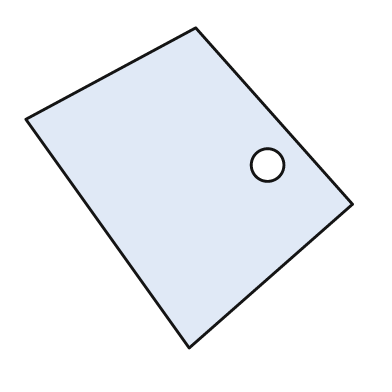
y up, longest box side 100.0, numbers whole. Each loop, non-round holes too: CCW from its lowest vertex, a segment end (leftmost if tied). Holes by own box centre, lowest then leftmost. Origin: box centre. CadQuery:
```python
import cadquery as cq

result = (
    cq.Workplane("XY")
    .moveTo(0.0, -49.0)
    .lineTo(50.0, -5.0)
    .lineTo(2.0, 49.0)
    .lineTo(-50.0, 21.0)
    .close()
    .moveTo(24.0, 7.0)
    .circle(5.0)
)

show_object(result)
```